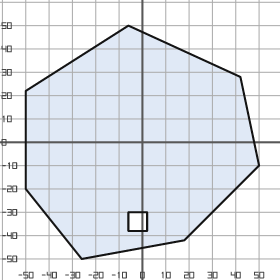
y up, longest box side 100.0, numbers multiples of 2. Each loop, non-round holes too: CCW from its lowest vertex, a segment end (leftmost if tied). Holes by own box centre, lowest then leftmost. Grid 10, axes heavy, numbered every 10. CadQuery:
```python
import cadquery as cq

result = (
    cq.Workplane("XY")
    .moveTo(-26.0, -50.0)
    .lineTo(18.0, -42.0)
    .lineTo(50.0, -10.0)
    .lineTo(42.0, 28.0)
    .lineTo(-6.0, 50.0)
    .lineTo(-50.0, 22.0)
    .lineTo(-50.0, -20.0)
    .close()
    .moveTo(-6.0, -38.0)
    .lineTo(2.0, -38.0)
    .lineTo(2.0, -30.0)
    .lineTo(-6.0, -30.0)
    .close()
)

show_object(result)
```